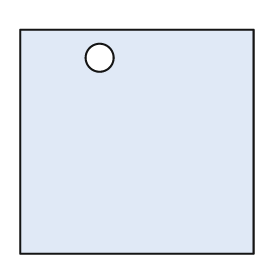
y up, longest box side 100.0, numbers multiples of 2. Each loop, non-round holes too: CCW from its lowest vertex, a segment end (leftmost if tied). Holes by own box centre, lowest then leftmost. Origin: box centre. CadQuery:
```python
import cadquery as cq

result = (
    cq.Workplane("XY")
    .moveTo(-50.0, -48.0)
    .lineTo(50.0, -48.0)
    .lineTo(50.0, 48.0)
    .lineTo(-50.0, 48.0)
    .close()
    .moveTo(-16.0, 36.0)
    .circle(6.0)
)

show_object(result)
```